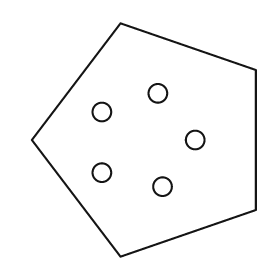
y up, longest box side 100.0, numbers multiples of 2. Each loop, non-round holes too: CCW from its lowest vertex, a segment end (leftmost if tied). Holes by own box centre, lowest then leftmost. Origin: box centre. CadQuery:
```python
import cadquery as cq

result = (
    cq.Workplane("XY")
    .moveTo(-10.0, -50.0)
    .lineTo(48.0, -30.0)
    .lineTo(48.0, 30.0)
    .lineTo(-10.0, 50.0)
    .lineTo(-48.0, 0.0)
    .close()
    .moveTo(8.0, -20.0)
    .circle(4.0)
    .moveTo(-18.0, -14.0)
    .circle(4.0)
    .moveTo(22.0, 0.0)
    .circle(4.0)
    .moveTo(-18.0, 12.0)
    .circle(4.0)
    .moveTo(6.0, 20.0)
    .circle(4.0)
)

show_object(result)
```